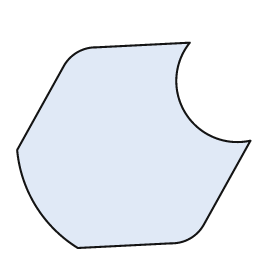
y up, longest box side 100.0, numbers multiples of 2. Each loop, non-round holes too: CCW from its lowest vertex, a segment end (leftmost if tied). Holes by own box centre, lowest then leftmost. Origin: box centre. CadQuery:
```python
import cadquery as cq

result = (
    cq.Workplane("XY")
    .moveTo(-24.0, -44.0)
    .lineTo(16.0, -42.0)
    .threePointArc((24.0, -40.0), (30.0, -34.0))
    .lineTo(50.0, 2.0)
    .threePointArc((22.0, 14.0), (24.0, 44.0))
    .lineTo(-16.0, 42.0)
    .threePointArc((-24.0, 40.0), (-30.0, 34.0))
    .lineTo(-50.0, -2.0)
    .threePointArc((-42.0, -26.0), (-24.0, -44.0))
    .close()
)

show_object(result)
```